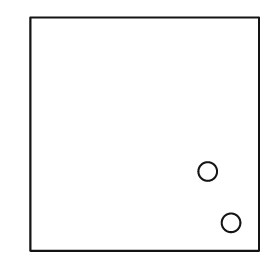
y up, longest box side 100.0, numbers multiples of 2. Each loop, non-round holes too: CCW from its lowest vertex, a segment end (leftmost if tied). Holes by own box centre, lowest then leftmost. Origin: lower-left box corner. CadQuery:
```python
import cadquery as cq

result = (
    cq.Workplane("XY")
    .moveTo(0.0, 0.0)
    .lineTo(98.0, 0.0)
    .lineTo(98.0, 100.0)
    .lineTo(0.0, 100.0)
    .close()
    .moveTo(86.0, 12.0)
    .circle(4.0)
    .moveTo(76.0, 34.0)
    .circle(4.0)
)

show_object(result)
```